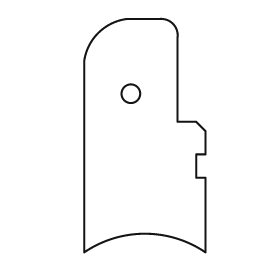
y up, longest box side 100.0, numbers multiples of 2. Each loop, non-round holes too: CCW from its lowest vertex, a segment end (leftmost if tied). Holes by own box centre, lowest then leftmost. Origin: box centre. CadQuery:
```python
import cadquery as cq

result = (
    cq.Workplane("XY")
    .moveTo(-26.0, -50.0)
    .threePointArc((0.0, -42.0), (26.0, -50.0))
    .lineTo(26.0, -18.0)
    .lineTo(22.0, -18.0)
    .lineTo(22.0, -8.0)
    .lineTo(26.0, -8.0)
    .lineTo(26.0, 2.0)
    .lineTo(22.0, 6.0)
    .lineTo(14.0, 6.0)
    .lineTo(14.0, 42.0)
    .threePointArc((12.0, 48.0), (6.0, 50.0))
    .lineTo(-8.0, 50.0)
    .threePointArc((-20.0, 44.0), (-26.0, 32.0))
    .close()
    .moveTo(-6.0, 18.0)
    .circle(4.0)
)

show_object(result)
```